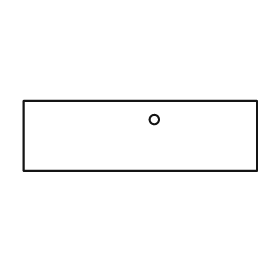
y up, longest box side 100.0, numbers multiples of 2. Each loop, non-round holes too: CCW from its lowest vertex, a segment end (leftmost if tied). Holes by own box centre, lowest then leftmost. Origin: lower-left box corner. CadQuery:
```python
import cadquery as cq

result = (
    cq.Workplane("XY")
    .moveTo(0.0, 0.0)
    .lineTo(100.0, 0.0)
    .lineTo(100.0, 30.0)
    .lineTo(0.0, 30.0)
    .close()
    .moveTo(56.0, 22.0)
    .circle(2.0)
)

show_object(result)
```